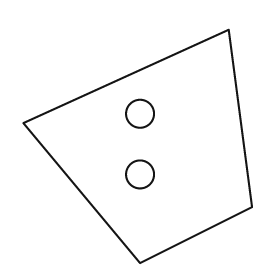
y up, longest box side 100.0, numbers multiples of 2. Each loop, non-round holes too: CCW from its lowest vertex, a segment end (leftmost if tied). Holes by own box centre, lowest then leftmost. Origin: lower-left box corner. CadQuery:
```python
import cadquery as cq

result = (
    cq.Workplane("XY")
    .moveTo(50.0, 0.0)
    .lineTo(98.0, 24.0)
    .lineTo(88.0, 100.0)
    .lineTo(0.0, 60.0)
    .close()
    .moveTo(50.0, 38.0)
    .circle(6.0)
    .moveTo(50.0, 64.0)
    .circle(6.0)
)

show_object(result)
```